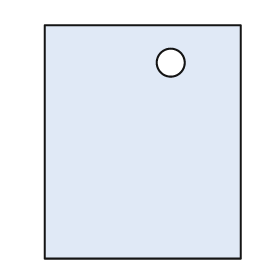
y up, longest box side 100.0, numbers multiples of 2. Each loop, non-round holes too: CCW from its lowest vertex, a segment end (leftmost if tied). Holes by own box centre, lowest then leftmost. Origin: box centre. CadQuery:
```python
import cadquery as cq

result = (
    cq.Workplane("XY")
    .moveTo(-42.0, -50.0)
    .lineTo(42.0, -50.0)
    .lineTo(42.0, 50.0)
    .lineTo(-42.0, 50.0)
    .close()
    .moveTo(12.0, 34.0)
    .circle(6.0)
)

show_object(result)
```